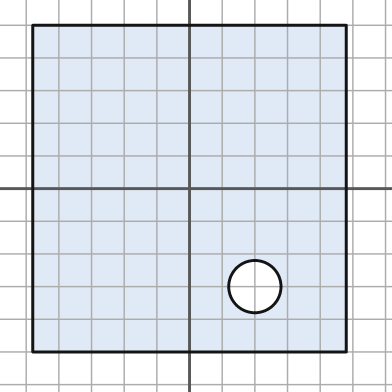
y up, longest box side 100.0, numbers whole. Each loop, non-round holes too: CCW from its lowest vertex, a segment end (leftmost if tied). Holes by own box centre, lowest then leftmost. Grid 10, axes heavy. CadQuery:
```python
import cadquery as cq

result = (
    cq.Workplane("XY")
    .moveTo(-48.0, -50.0)
    .lineTo(48.0, -50.0)
    .lineTo(48.0, 50.0)
    .lineTo(-48.0, 50.0)
    .close()
    .moveTo(20.0, -30.0)
    .circle(8.0)
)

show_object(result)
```